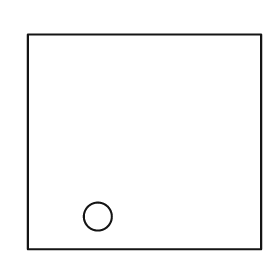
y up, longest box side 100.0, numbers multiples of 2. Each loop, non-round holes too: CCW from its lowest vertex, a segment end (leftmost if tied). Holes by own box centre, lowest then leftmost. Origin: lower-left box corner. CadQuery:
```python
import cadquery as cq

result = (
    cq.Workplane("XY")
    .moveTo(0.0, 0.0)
    .lineTo(100.0, 0.0)
    .lineTo(100.0, 92.0)
    .lineTo(0.0, 92.0)
    .close()
    .moveTo(30.0, 14.0)
    .circle(6.0)
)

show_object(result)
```